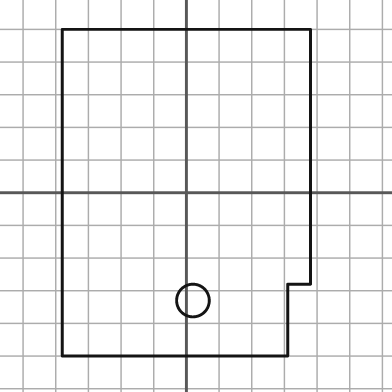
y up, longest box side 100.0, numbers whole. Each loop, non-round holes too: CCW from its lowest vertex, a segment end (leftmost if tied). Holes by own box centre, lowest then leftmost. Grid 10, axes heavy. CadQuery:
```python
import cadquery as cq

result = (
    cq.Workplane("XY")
    .moveTo(-38.0, -50.0)
    .lineTo(31.0, -50.0)
    .lineTo(31.0, -28.0)
    .lineTo(38.0, -28.0)
    .lineTo(38.0, 50.0)
    .lineTo(-38.0, 50.0)
    .close()
    .moveTo(2.0, -33.0)
    .circle(5.0)
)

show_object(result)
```